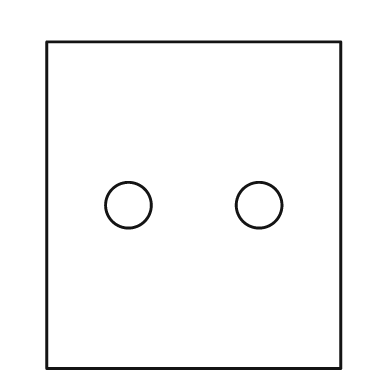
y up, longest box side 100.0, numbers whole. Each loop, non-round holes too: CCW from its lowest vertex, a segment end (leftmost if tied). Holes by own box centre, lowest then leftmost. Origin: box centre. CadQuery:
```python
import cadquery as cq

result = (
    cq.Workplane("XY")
    .moveTo(-45.0, -50.0)
    .lineTo(45.0, -50.0)
    .lineTo(45.0, 50.0)
    .lineTo(-45.0, 50.0)
    .close()
    .moveTo(-20.0, 0.0)
    .circle(7.0)
    .moveTo(20.0, 0.0)
    .circle(7.0)
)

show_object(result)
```